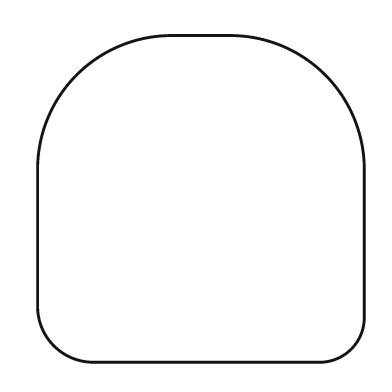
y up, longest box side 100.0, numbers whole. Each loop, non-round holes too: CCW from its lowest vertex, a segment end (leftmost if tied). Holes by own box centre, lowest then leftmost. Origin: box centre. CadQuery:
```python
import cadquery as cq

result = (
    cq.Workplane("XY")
    .moveTo(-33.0, -50.0)
    .lineTo(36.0, -50.0)
    .threePointArc((46.0, -46.0), (50.0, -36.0))
    .lineTo(50.0, 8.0)
    .threePointArc((38.0, 38.0), (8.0, 50.0))
    .lineTo(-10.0, 50.0)
    .threePointArc((-38.0, 38.0), (-50.0, 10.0))
    .lineTo(-50.0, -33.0)
    .threePointArc((-45.0, -45.0), (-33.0, -50.0))
    .close()
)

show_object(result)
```